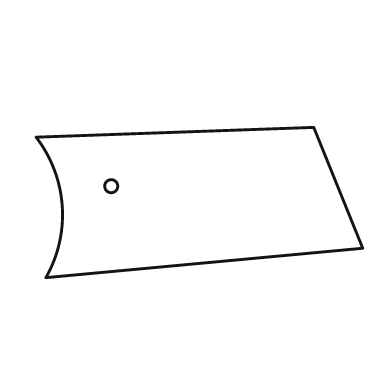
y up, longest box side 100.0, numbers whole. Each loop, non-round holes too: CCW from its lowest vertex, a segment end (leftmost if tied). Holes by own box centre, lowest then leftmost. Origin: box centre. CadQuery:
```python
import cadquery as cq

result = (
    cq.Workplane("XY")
    .moveTo(-47.0, -23.0)
    .lineTo(50.0, -14.0)
    .lineTo(35.0, 23.0)
    .lineTo(-50.0, 20.0)
    .threePointArc((-42.0, -1.0), (-47.0, -23.0))
    .close()
    .moveTo(-27.0, 5.0)
    .circle(2.0)
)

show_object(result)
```